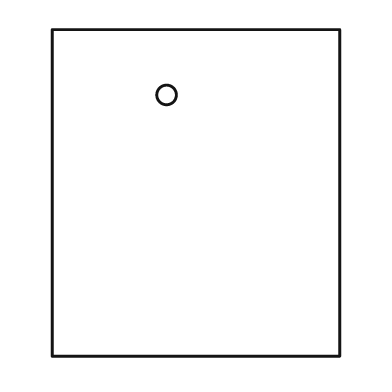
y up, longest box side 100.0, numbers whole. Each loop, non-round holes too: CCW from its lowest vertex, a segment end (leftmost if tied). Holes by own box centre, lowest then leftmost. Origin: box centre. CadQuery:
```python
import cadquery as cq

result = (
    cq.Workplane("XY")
    .moveTo(-44.0, -50.0)
    .lineTo(44.0, -50.0)
    .lineTo(44.0, 50.0)
    .lineTo(-44.0, 50.0)
    .close()
    .moveTo(-9.0, 30.0)
    .circle(3.0)
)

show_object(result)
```